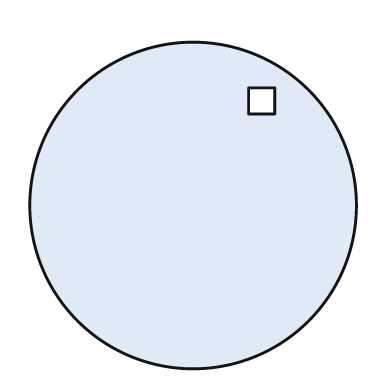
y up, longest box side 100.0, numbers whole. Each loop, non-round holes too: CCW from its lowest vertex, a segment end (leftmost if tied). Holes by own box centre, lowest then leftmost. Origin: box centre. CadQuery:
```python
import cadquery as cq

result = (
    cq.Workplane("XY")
    .moveTo(0.0, 0.0)
    .circle(50.0)
    .moveTo(17.0, 28.0)
    .lineTo(25.0, 28.0)
    .lineTo(25.0, 36.0)
    .lineTo(17.0, 36.0)
    .close()
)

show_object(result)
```